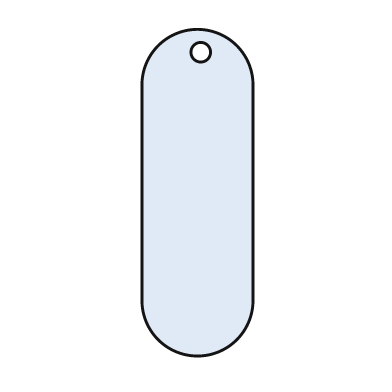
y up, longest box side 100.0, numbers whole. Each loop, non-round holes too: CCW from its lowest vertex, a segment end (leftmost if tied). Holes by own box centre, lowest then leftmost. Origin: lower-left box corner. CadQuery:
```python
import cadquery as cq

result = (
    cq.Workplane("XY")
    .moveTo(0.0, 17.0)
    .threePointArc((17.0, 0.0), (34.0, 17.0))
    .lineTo(34.0, 83.0)
    .threePointArc((17.0, 100.0), (0.0, 83.0))
    .close()
    .moveTo(18.0, 93.0)
    .circle(3.0)
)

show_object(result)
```